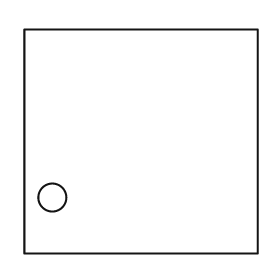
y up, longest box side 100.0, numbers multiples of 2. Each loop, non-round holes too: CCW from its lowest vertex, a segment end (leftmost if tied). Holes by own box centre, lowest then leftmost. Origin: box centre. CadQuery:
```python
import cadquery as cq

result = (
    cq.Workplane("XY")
    .moveTo(-50.0, -48.0)
    .lineTo(50.0, -48.0)
    .lineTo(50.0, 48.0)
    .lineTo(-50.0, 48.0)
    .close()
    .moveTo(-38.0, -24.0)
    .circle(6.0)
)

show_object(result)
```